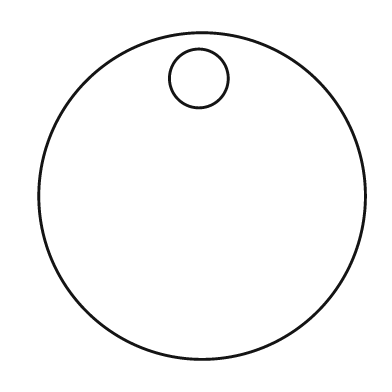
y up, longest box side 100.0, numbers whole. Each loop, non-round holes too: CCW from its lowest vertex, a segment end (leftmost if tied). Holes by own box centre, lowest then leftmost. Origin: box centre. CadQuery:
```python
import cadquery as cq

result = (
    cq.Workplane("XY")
    .moveTo(0.0, 0.0)
    .circle(50.0)
    .moveTo(-1.0, 36.0)
    .circle(9.0)
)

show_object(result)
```